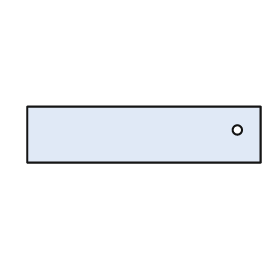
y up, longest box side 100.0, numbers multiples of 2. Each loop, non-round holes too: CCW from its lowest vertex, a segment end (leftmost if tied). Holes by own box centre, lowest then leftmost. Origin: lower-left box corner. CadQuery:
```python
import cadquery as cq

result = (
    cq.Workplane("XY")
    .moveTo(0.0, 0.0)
    .lineTo(100.0, 0.0)
    .lineTo(100.0, 24.0)
    .lineTo(0.0, 24.0)
    .close()
    .moveTo(90.0, 14.0)
    .circle(2.0)
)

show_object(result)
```